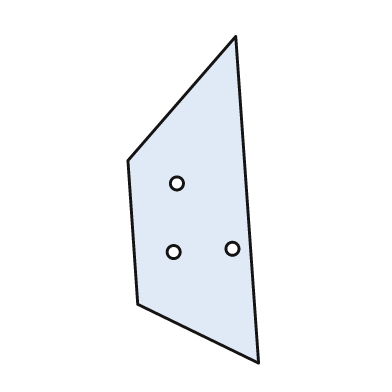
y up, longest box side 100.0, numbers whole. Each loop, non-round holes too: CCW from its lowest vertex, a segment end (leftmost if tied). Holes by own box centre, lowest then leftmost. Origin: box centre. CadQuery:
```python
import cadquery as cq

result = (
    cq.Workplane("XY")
    .moveTo(20.0, -50.0)
    .lineTo(13.0, 50.0)
    .lineTo(-20.0, 12.0)
    .lineTo(-17.0, -32.0)
    .close()
    .moveTo(-6.0, -16.0)
    .circle(2.0)
    .moveTo(12.0, -15.0)
    .circle(2.0)
    .moveTo(-5.0, 5.0)
    .circle(2.0)
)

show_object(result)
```